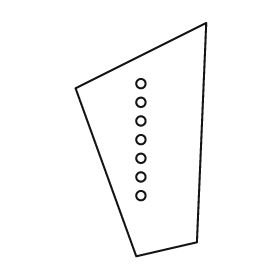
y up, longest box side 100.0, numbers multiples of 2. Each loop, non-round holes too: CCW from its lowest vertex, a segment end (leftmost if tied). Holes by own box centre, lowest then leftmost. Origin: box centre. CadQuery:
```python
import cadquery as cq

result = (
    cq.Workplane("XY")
    .moveTo(-2.0, -50.0)
    .lineTo(24.0, -44.0)
    .lineTo(28.0, 50.0)
    .lineTo(-28.0, 22.0)
    .close()
    .moveTo(0.0, -24.0)
    .circle(2.0)
    .moveTo(0.0, -16.0)
    .circle(2.0)
    .moveTo(0.0, -8.0)
    .circle(2.0)
    .moveTo(0.0, 0.0)
    .circle(2.0)
    .moveTo(0.0, 8.0)
    .circle(2.0)
    .moveTo(0.0, 16.0)
    .circle(2.0)
    .moveTo(0.0, 24.0)
    .circle(2.0)
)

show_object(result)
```